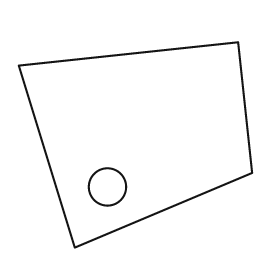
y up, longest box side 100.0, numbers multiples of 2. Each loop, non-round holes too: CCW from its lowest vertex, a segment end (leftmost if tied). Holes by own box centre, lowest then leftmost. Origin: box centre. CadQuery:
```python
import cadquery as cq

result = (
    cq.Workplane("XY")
    .moveTo(-26.0, -44.0)
    .lineTo(50.0, -12.0)
    .lineTo(44.0, 44.0)
    .lineTo(-50.0, 34.0)
    .close()
    .moveTo(-12.0, -18.0)
    .circle(8.0)
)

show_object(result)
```